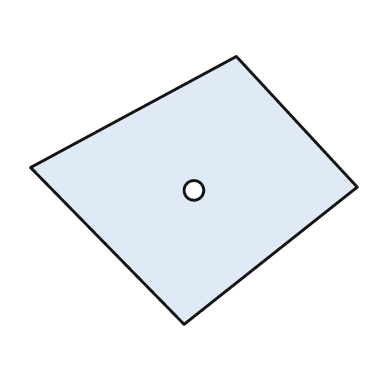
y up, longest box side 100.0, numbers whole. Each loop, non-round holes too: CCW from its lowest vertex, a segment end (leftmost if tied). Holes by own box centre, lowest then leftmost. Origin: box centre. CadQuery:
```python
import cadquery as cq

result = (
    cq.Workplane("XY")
    .moveTo(-3.0, -41.0)
    .lineTo(50.0, 1.0)
    .lineTo(13.0, 41.0)
    .lineTo(-50.0, 7.0)
    .close()
    .moveTo(0.0, 0.0)
    .circle(3.0)
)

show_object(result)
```